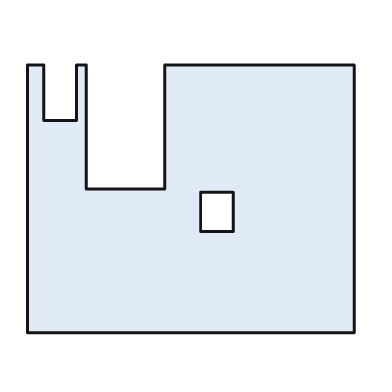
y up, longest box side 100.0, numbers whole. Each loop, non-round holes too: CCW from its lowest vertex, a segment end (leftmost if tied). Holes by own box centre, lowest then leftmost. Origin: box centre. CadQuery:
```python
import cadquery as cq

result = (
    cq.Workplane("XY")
    .moveTo(-50.0, -41.0)
    .lineTo(50.0, -41.0)
    .lineTo(50.0, 41.0)
    .lineTo(-8.0, 41.0)
    .lineTo(-8.0, 3.0)
    .lineTo(-32.0, 3.0)
    .lineTo(-32.0, 41.0)
    .lineTo(-35.0, 41.0)
    .lineTo(-35.0, 24.0)
    .lineTo(-45.0, 24.0)
    .lineTo(-45.0, 41.0)
    .lineTo(-50.0, 41.0)
    .close()
    .moveTo(3.0, -10.0)
    .lineTo(13.0, -10.0)
    .lineTo(13.0, 2.0)
    .lineTo(3.0, 2.0)
    .close()
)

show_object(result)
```